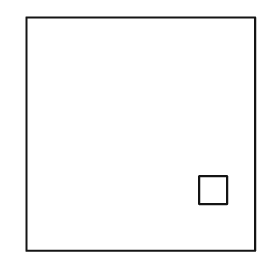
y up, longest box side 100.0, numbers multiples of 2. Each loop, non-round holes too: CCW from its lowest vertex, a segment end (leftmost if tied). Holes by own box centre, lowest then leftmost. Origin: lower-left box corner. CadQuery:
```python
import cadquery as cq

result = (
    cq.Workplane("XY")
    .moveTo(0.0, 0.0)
    .lineTo(98.0, 0.0)
    .lineTo(98.0, 100.0)
    .lineTo(0.0, 100.0)
    .close()
    .moveTo(74.0, 20.0)
    .lineTo(86.0, 20.0)
    .lineTo(86.0, 32.0)
    .lineTo(74.0, 32.0)
    .close()
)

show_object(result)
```